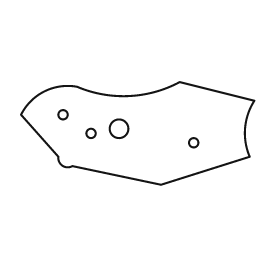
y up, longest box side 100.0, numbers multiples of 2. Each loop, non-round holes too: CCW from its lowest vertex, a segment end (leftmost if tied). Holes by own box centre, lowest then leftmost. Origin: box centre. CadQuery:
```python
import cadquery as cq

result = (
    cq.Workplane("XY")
    .moveTo(10.0, -22.0)
    .lineTo(48.0, -10.0)
    .threePointArc((46.0, 2.0), (50.0, 14.0))
    .lineTo(18.0, 22.0)
    .threePointArc((-4.0, 16.0), (-26.0, 20.0))
    .threePointArc((-40.0, 18.0), (-50.0, 8.0))
    .lineTo(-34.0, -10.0)
    .threePointArc((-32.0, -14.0), (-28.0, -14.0))
    .close()
    .moveTo(24.0, -4.0)
    .circle(2.0)
    .moveTo(-20.0, 0.0)
    .circle(2.0)
    .moveTo(-8.0, 2.0)
    .circle(4.0)
    .moveTo(-32.0, 8.0)
    .circle(2.0)
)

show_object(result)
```